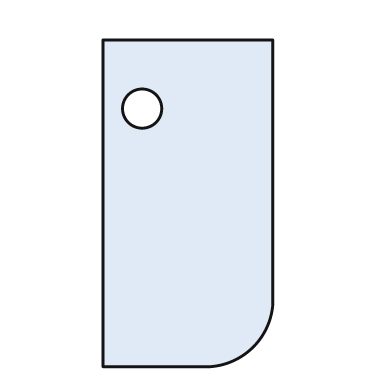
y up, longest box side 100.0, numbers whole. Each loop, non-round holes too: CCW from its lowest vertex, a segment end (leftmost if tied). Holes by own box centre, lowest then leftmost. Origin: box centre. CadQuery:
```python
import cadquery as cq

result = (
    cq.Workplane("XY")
    .moveTo(-26.0, -50.0)
    .lineTo(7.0, -50.0)
    .threePointArc((20.0, -44.0), (26.0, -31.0))
    .lineTo(26.0, 50.0)
    .lineTo(-26.0, 50.0)
    .close()
    .moveTo(-14.0, 29.0)
    .circle(6.0)
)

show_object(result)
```